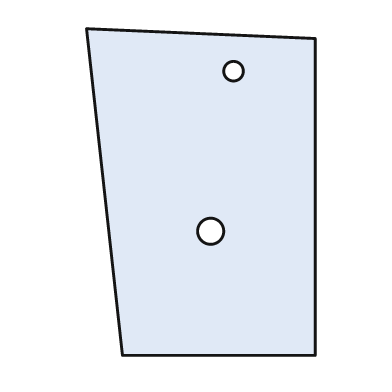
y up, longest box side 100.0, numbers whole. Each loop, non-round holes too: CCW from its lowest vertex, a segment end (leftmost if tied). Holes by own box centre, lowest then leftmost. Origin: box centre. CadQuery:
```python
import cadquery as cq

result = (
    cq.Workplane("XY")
    .moveTo(-24.0, -50.0)
    .lineTo(35.0, -50.0)
    .lineTo(35.0, 47.0)
    .lineTo(-35.0, 50.0)
    .close()
    .moveTo(3.0, -12.0)
    .circle(4.0)
    .moveTo(10.0, 37.0)
    .circle(3.0)
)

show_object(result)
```